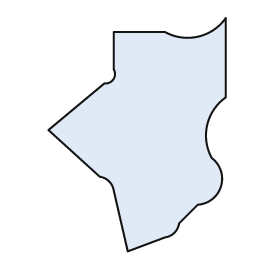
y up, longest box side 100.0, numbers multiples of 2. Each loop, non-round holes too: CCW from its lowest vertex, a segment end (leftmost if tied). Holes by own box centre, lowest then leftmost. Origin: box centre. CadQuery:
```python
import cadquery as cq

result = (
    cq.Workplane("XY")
    .moveTo(-4.0, -50.0)
    .lineTo(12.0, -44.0)
    .threePointArc((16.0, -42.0), (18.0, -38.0))
    .lineTo(26.0, -30.0)
    .threePointArc((36.0, -22.0), (32.0, -10.0))
    .threePointArc((30.0, 4.0), (38.0, 16.0))
    .lineTo(38.0, 50.0)
    .threePointArc((26.0, 42.0), (12.0, 44.0))
    .lineTo(-10.0, 44.0)
    .lineTo(-10.0, 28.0)
    .threePointArc((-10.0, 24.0), (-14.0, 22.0))
    .lineTo(-38.0, 2.0)
    .lineTo(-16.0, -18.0)
    .threePointArc((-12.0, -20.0), (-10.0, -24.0))
    .close()
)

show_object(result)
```